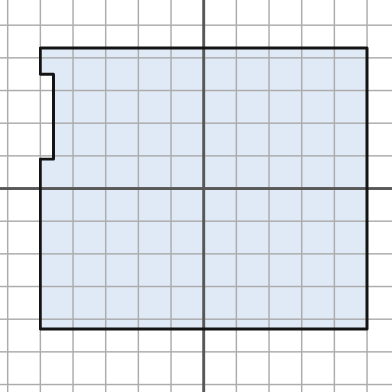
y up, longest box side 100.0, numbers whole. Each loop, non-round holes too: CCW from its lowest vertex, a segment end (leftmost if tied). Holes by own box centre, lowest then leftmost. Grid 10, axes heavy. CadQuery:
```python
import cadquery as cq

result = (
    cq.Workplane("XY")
    .moveTo(-50.0, -43.0)
    .lineTo(50.0, -43.0)
    .lineTo(50.0, 43.0)
    .lineTo(-50.0, 43.0)
    .lineTo(-50.0, 35.0)
    .lineTo(-46.0, 35.0)
    .lineTo(-46.0, 9.0)
    .lineTo(-50.0, 9.0)
    .close()
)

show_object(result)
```